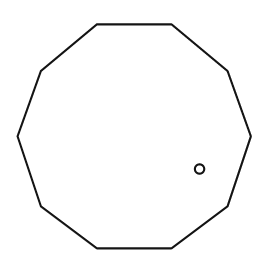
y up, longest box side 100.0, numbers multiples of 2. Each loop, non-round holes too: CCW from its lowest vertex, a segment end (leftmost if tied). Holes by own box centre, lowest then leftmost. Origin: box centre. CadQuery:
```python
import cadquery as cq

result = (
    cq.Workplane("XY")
    .moveTo(-16.0, -48.0)
    .lineTo(16.0, -48.0)
    .lineTo(40.0, -30.0)
    .lineTo(50.0, 0.0)
    .lineTo(40.0, 28.0)
    .lineTo(16.0, 48.0)
    .lineTo(-16.0, 48.0)
    .lineTo(-40.0, 28.0)
    .lineTo(-50.0, 0.0)
    .lineTo(-40.0, -30.0)
    .close()
    .moveTo(28.0, -14.0)
    .circle(2.0)
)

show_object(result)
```